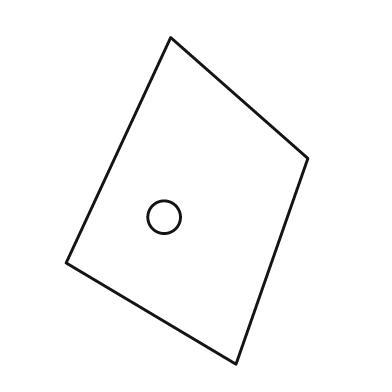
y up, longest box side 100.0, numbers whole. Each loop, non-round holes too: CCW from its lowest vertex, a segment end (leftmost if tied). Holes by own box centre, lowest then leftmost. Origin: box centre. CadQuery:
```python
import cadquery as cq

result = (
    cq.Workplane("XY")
    .moveTo(15.0, -50.0)
    .lineTo(37.0, 13.0)
    .lineTo(-5.0, 50.0)
    .lineTo(-37.0, -19.0)
    .close()
    .moveTo(-7.0, -5.0)
    .circle(5.0)
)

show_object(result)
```